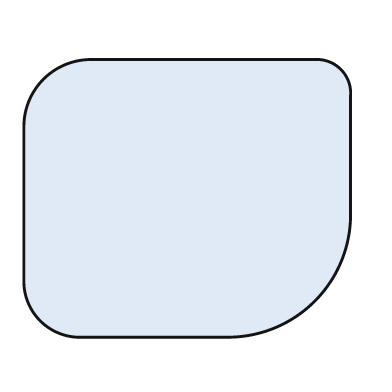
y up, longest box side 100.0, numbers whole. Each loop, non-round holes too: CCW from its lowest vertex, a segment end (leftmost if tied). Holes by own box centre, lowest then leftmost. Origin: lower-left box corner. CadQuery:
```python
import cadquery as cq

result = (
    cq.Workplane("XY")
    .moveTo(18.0, 0.0)
    .lineTo(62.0, 0.0)
    .threePointArc((89.0, 11.0), (100.0, 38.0))
    .lineTo(100.0, 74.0)
    .threePointArc((97.0, 82.0), (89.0, 85.0))
    .lineTo(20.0, 85.0)
    .threePointArc((6.0, 79.0), (0.0, 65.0))
    .lineTo(0.0, 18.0)
    .threePointArc((5.0, 5.0), (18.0, 0.0))
    .close()
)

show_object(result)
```